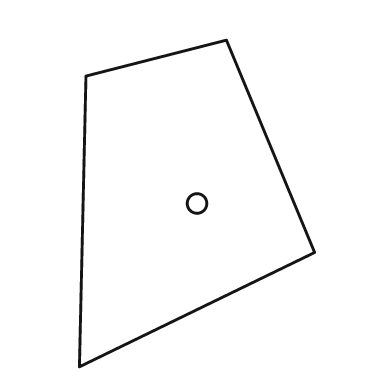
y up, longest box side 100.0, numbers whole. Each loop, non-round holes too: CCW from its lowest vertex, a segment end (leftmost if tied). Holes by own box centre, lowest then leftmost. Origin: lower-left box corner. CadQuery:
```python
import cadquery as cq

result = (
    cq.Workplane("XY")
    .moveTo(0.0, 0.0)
    .lineTo(72.0, 35.0)
    .lineTo(45.0, 100.0)
    .lineTo(2.0, 89.0)
    .close()
    .moveTo(36.0, 50.0)
    .circle(3.0)
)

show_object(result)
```